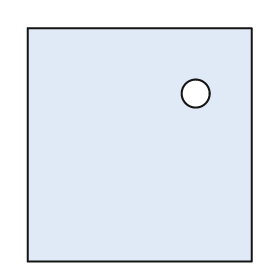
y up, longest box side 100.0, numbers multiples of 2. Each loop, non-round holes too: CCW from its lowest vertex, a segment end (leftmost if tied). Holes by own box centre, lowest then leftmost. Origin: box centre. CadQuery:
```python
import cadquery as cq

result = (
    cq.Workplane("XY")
    .moveTo(-48.0, -50.0)
    .lineTo(48.0, -50.0)
    .lineTo(48.0, 50.0)
    .lineTo(-48.0, 50.0)
    .close()
    .moveTo(24.0, 22.0)
    .circle(6.0)
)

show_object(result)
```